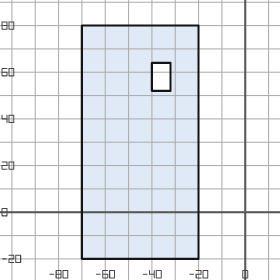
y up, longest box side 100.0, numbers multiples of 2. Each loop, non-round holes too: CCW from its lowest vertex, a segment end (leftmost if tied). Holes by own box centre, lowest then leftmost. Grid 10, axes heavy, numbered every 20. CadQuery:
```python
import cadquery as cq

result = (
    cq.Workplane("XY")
    .moveTo(-70.0, -20.0)
    .lineTo(-20.0, -20.0)
    .lineTo(-20.0, 80.0)
    .lineTo(-70.0, 80.0)
    .close()
    .moveTo(-40.0, 52.0)
    .lineTo(-32.0, 52.0)
    .lineTo(-32.0, 64.0)
    .lineTo(-40.0, 64.0)
    .close()
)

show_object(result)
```